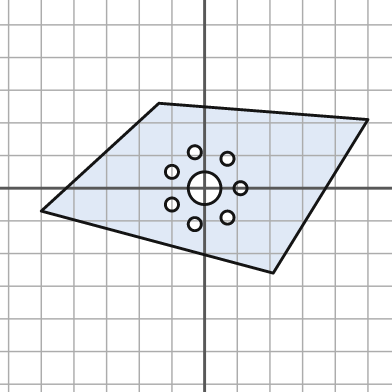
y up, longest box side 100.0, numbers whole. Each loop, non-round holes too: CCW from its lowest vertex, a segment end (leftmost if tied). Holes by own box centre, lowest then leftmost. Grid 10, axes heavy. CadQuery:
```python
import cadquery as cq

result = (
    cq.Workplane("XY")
    .moveTo(21.0, -26.0)
    .lineTo(50.0, 21.0)
    .lineTo(-14.0, 26.0)
    .lineTo(-50.0, -7.0)
    .close()
    .moveTo(-3.0, -11.0)
    .circle(2.0)
    .moveTo(7.0, -9.0)
    .circle(2.0)
    .moveTo(-10.0, -5.0)
    .circle(2.0)
    .moveTo(0.0, 0.0)
    .circle(5.0)
    .moveTo(11.0, 0.0)
    .circle(2.0)
    .moveTo(-10.0, 5.0)
    .circle(2.0)
    .moveTo(7.0, 9.0)
    .circle(2.0)
    .moveTo(-3.0, 11.0)
    .circle(2.0)
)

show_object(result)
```